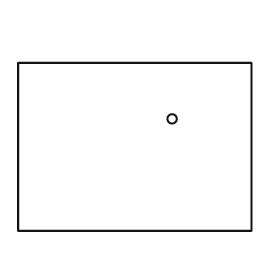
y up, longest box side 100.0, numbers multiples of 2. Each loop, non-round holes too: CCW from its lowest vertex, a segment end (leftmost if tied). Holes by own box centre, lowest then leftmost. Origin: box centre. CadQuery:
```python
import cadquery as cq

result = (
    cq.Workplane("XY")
    .moveTo(-50.0, -36.0)
    .lineTo(50.0, -36.0)
    .lineTo(50.0, 36.0)
    .lineTo(-50.0, 36.0)
    .close()
    .moveTo(16.0, 12.0)
    .circle(2.0)
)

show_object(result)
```